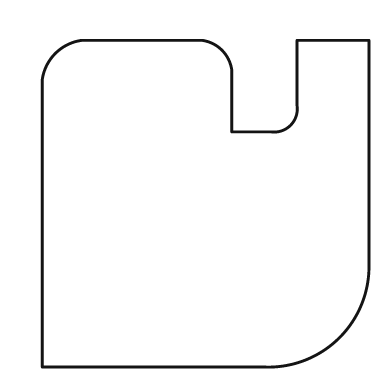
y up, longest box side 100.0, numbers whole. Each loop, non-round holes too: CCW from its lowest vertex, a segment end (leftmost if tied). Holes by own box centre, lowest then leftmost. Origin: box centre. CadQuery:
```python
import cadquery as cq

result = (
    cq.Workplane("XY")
    .moveTo(-50.0, -50.0)
    .lineTo(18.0, -50.0)
    .threePointArc((41.0, -41.0), (50.0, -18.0))
    .lineTo(50.0, 50.0)
    .lineTo(28.0, 50.0)
    .lineTo(28.0, 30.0)
    .threePointArc((26.0, 24.0), (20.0, 22.0))
    .lineTo(8.0, 22.0)
    .lineTo(8.0, 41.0)
    .threePointArc((5.0, 47.0), (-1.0, 50.0))
    .lineTo(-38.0, 50.0)
    .threePointArc((-46.0, 46.0), (-50.0, 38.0))
    .close()
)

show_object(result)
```